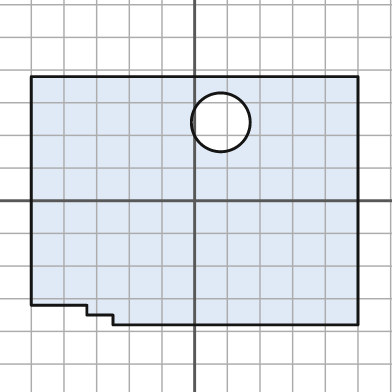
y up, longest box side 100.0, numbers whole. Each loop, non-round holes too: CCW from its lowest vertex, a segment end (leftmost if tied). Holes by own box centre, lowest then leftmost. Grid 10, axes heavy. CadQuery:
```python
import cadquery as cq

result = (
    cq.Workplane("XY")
    .moveTo(-25.0, -38.0)
    .lineTo(50.0, -38.0)
    .lineTo(50.0, 38.0)
    .lineTo(-50.0, 38.0)
    .lineTo(-50.0, -32.0)
    .lineTo(-33.0, -32.0)
    .lineTo(-33.0, -35.0)
    .lineTo(-25.0, -35.0)
    .close()
    .moveTo(8.0, 24.0)
    .circle(9.0)
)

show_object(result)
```